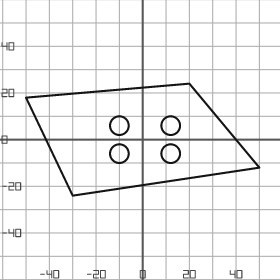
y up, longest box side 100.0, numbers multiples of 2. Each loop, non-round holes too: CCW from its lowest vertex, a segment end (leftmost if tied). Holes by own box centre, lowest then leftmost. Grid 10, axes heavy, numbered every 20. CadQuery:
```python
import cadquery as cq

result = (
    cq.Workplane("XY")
    .moveTo(-30.0, -24.0)
    .lineTo(50.0, -12.0)
    .lineTo(20.0, 24.0)
    .lineTo(-50.0, 18.0)
    .close()
    .moveTo(-10.0, -6.0)
    .circle(4.0)
    .moveTo(12.0, -6.0)
    .circle(4.0)
    .moveTo(-10.0, 6.0)
    .circle(4.0)
    .moveTo(12.0, 6.0)
    .circle(4.0)
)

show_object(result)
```